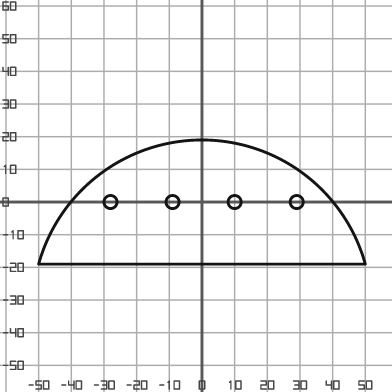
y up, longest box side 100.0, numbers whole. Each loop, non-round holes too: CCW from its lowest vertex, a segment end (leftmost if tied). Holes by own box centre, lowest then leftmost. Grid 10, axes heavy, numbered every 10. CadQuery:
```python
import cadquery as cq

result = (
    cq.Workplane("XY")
    .moveTo(-50.0, -19.0)
    .lineTo(50.0, -19.0)
    .threePointArc((0.0, 19.0), (-50.0, -19.0))
    .close()
    .moveTo(-28.0, 0.0)
    .circle(2.0)
    .moveTo(-9.0, 0.0)
    .circle(2.0)
    .moveTo(10.0, 0.0)
    .circle(2.0)
    .moveTo(29.0, 0.0)
    .circle(2.0)
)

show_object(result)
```